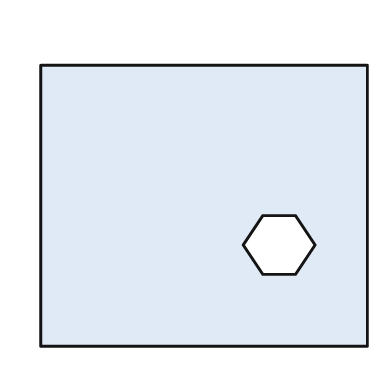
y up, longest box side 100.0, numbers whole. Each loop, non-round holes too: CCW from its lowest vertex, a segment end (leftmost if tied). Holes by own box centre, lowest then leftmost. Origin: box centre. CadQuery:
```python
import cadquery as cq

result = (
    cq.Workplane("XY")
    .moveTo(-50.0, -43.0)
    .lineTo(50.0, -43.0)
    .lineTo(50.0, 43.0)
    .lineTo(-50.0, 43.0)
    .close()
    .moveTo(18.0, -21.0)
    .lineTo(28.0, -21.0)
    .lineTo(34.0, -12.0)
    .lineTo(28.0, -3.0)
    .lineTo(18.0, -3.0)
    .lineTo(12.0, -12.0)
    .close()
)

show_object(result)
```